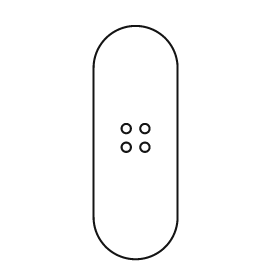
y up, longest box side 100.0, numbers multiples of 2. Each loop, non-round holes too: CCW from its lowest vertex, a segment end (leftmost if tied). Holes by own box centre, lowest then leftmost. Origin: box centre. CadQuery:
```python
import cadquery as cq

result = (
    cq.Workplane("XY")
    .moveTo(-18.0, -32.0)
    .threePointArc((0.0, -50.0), (18.0, -32.0))
    .lineTo(18.0, 32.0)
    .threePointArc((0.0, 50.0), (-18.0, 32.0))
    .close()
    .moveTo(-4.0, -2.0)
    .circle(2.0)
    .moveTo(4.0, -2.0)
    .circle(2.0)
    .moveTo(-4.0, 6.0)
    .circle(2.0)
    .moveTo(4.0, 6.0)
    .circle(2.0)
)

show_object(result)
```